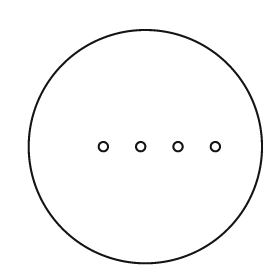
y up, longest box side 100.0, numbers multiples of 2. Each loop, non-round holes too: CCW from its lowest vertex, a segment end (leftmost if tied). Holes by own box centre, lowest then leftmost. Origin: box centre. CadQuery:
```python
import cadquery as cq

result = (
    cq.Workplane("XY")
    .moveTo(0.0, 0.0)
    .circle(50.0)
    .moveTo(-18.0, 0.0)
    .circle(2.0)
    .moveTo(-2.0, 0.0)
    .circle(2.0)
    .moveTo(14.0, 0.0)
    .circle(2.0)
    .moveTo(30.0, 0.0)
    .circle(2.0)
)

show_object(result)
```